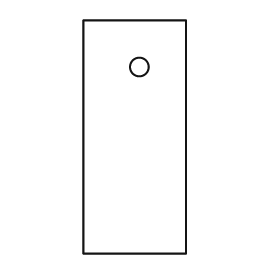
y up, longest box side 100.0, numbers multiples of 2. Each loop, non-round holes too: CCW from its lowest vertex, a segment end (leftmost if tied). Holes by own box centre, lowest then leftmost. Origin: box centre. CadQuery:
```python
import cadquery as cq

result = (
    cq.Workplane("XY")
    .moveTo(-22.0, -50.0)
    .lineTo(22.0, -50.0)
    .lineTo(22.0, 50.0)
    .lineTo(-22.0, 50.0)
    .close()
    .moveTo(2.0, 30.0)
    .circle(4.0)
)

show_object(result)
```